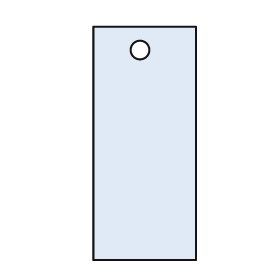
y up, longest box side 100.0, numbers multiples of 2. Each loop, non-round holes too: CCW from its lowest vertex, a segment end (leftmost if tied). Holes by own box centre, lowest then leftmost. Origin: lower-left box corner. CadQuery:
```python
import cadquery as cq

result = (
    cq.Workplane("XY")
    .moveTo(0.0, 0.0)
    .lineTo(44.0, 0.0)
    .lineTo(44.0, 100.0)
    .lineTo(0.0, 100.0)
    .close()
    .moveTo(20.0, 90.0)
    .circle(4.0)
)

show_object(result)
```